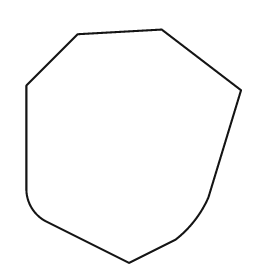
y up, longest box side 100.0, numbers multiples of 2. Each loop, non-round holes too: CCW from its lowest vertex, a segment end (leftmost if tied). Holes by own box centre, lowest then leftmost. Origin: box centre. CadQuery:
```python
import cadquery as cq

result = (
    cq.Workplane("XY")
    .moveTo(-2.0, -50.0)
    .lineTo(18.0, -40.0)
    .threePointArc((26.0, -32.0), (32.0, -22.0))
    .lineTo(46.0, 24.0)
    .lineTo(12.0, 50.0)
    .lineTo(-24.0, 48.0)
    .lineTo(-46.0, 26.0)
    .lineTo(-46.0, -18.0)
    .threePointArc((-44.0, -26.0), (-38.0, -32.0))
    .close()
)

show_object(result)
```